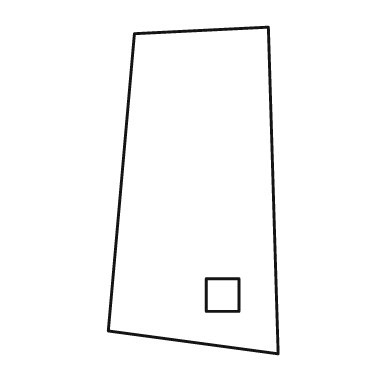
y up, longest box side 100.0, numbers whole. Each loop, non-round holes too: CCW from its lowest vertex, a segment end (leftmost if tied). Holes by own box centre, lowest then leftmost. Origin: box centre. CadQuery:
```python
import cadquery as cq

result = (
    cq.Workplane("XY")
    .moveTo(26.0, -50.0)
    .lineTo(23.0, 50.0)
    .lineTo(-18.0, 48.0)
    .lineTo(-26.0, -43.0)
    .close()
    .moveTo(4.0, -37.0)
    .lineTo(14.0, -37.0)
    .lineTo(14.0, -27.0)
    .lineTo(4.0, -27.0)
    .close()
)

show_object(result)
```